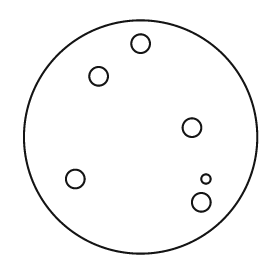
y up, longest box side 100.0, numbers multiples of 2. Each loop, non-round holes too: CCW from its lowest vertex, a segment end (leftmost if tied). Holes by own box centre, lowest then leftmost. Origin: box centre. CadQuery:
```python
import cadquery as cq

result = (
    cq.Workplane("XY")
    .moveTo(0.0, 0.0)
    .circle(50.0)
    .moveTo(26.0, -28.0)
    .circle(4.0)
    .moveTo(-28.0, -18.0)
    .circle(4.0)
    .moveTo(28.0, -18.0)
    .circle(2.0)
    .moveTo(22.0, 4.0)
    .circle(4.0)
    .moveTo(-18.0, 26.0)
    .circle(4.0)
    .moveTo(0.0, 40.0)
    .circle(4.0)
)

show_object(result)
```